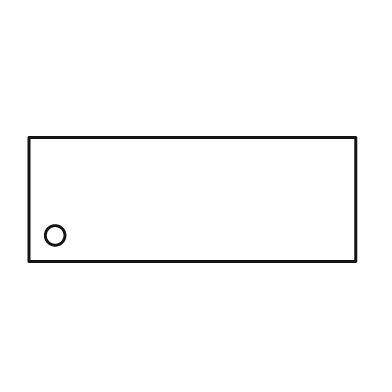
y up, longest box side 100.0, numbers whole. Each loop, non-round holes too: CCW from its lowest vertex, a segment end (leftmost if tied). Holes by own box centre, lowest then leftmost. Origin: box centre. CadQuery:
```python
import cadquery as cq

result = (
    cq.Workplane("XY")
    .moveTo(-50.0, -19.0)
    .lineTo(50.0, -19.0)
    .lineTo(50.0, 19.0)
    .lineTo(-50.0, 19.0)
    .close()
    .moveTo(-42.0, -11.0)
    .circle(3.0)
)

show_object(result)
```